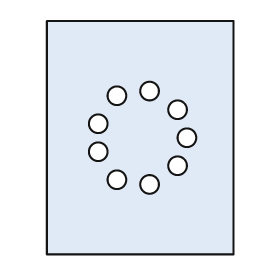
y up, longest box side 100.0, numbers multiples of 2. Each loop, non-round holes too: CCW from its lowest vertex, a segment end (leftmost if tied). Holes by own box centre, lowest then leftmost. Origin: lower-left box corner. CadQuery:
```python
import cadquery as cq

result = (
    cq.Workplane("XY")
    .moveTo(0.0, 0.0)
    .lineTo(80.0, 0.0)
    .lineTo(80.0, 100.0)
    .lineTo(0.0, 100.0)
    .close()
    .moveTo(44.0, 30.0)
    .circle(4.0)
    .moveTo(30.0, 32.0)
    .circle(4.0)
    .moveTo(56.0, 38.0)
    .circle(4.0)
    .moveTo(22.0, 44.0)
    .circle(4.0)
    .moveTo(60.0, 50.0)
    .circle(4.0)
    .moveTo(22.0, 56.0)
    .circle(4.0)
    .moveTo(56.0, 62.0)
    .circle(4.0)
    .moveTo(30.0, 68.0)
    .circle(4.0)
    .moveTo(44.0, 70.0)
    .circle(4.0)
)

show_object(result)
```